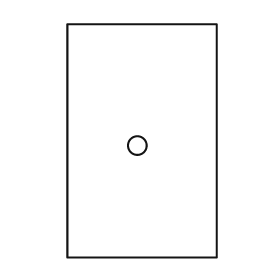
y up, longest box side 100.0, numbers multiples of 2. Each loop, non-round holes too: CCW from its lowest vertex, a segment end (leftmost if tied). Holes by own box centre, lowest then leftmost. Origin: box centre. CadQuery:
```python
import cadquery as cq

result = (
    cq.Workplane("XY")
    .moveTo(-32.0, -50.0)
    .lineTo(32.0, -50.0)
    .lineTo(32.0, 50.0)
    .lineTo(-32.0, 50.0)
    .close()
    .moveTo(-2.0, -2.0)
    .circle(4.0)
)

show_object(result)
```